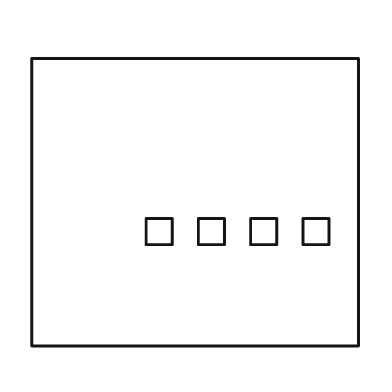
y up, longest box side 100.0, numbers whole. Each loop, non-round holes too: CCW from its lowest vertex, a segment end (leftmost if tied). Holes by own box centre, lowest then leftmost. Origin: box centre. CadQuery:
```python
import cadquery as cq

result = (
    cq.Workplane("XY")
    .moveTo(-50.0, -44.0)
    .lineTo(50.0, -44.0)
    .lineTo(50.0, 44.0)
    .lineTo(-50.0, 44.0)
    .close()
    .moveTo(-15.0, -13.0)
    .lineTo(-7.0, -13.0)
    .lineTo(-7.0, -5.0)
    .lineTo(-15.0, -5.0)
    .close()
    .moveTo(1.0, -13.0)
    .lineTo(9.0, -13.0)
    .lineTo(9.0, -5.0)
    .lineTo(1.0, -5.0)
    .close()
    .moveTo(17.0, -13.0)
    .lineTo(25.0, -13.0)
    .lineTo(25.0, -5.0)
    .lineTo(17.0, -5.0)
    .close()
    .moveTo(33.0, -13.0)
    .lineTo(41.0, -13.0)
    .lineTo(41.0, -5.0)
    .lineTo(33.0, -5.0)
    .close()
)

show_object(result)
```